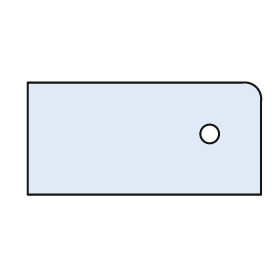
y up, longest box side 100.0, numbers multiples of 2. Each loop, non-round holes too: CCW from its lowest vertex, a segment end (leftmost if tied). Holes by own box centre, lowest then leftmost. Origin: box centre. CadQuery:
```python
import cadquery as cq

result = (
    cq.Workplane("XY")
    .moveTo(-50.0, -24.0)
    .lineTo(50.0, -24.0)
    .lineTo(50.0, 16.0)
    .threePointArc((48.0, 22.0), (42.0, 24.0))
    .lineTo(-50.0, 24.0)
    .close()
    .moveTo(28.0, 2.0)
    .circle(4.0)
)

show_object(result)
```